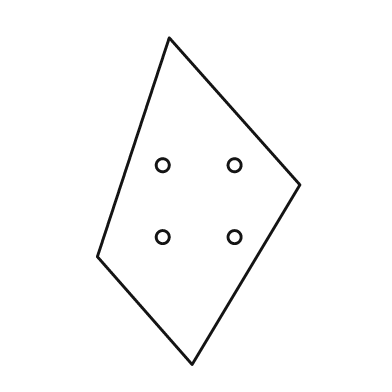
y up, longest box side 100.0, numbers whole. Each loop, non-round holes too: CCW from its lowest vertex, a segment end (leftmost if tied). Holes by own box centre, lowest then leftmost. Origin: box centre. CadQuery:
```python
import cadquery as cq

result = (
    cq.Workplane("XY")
    .moveTo(-2.0, -50.0)
    .lineTo(31.0, 5.0)
    .lineTo(-9.0, 50.0)
    .lineTo(-31.0, -17.0)
    .close()
    .moveTo(-11.0, -11.0)
    .circle(2.0)
    .moveTo(11.0, -11.0)
    .circle(2.0)
    .moveTo(-11.0, 11.0)
    .circle(2.0)
    .moveTo(11.0, 11.0)
    .circle(2.0)
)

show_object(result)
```